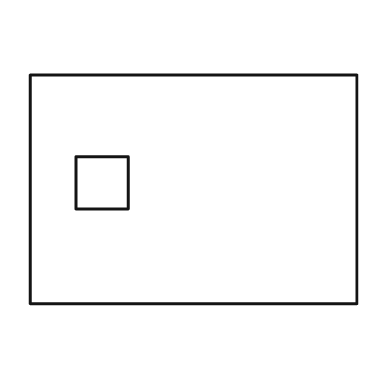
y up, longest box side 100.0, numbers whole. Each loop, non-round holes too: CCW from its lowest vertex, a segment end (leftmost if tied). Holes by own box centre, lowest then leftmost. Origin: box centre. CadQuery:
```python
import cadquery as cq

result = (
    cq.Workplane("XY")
    .moveTo(-50.0, -35.0)
    .lineTo(50.0, -35.0)
    .lineTo(50.0, 35.0)
    .lineTo(-50.0, 35.0)
    .close()
    .moveTo(-36.0, -6.0)
    .lineTo(-20.0, -6.0)
    .lineTo(-20.0, 10.0)
    .lineTo(-36.0, 10.0)
    .close()
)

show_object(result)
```